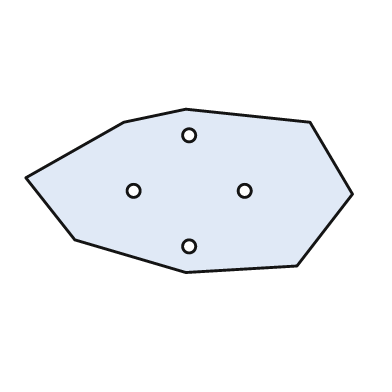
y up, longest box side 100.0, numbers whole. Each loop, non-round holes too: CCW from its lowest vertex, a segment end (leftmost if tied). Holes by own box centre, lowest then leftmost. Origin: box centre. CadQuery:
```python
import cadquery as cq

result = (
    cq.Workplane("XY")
    .moveTo(-1.0, -25.0)
    .lineTo(33.0, -23.0)
    .lineTo(50.0, -1.0)
    .lineTo(37.0, 21.0)
    .lineTo(-1.0, 25.0)
    .lineTo(-20.0, 21.0)
    .lineTo(-50.0, 4.0)
    .lineTo(-35.0, -15.0)
    .close()
    .moveTo(0.0, -17.0)
    .circle(2.0)
    .moveTo(-17.0, 0.0)
    .circle(2.0)
    .moveTo(17.0, 0.0)
    .circle(2.0)
    .moveTo(0.0, 17.0)
    .circle(2.0)
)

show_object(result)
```